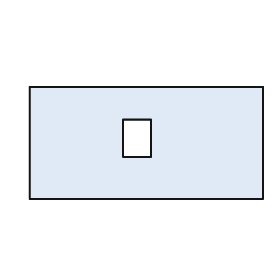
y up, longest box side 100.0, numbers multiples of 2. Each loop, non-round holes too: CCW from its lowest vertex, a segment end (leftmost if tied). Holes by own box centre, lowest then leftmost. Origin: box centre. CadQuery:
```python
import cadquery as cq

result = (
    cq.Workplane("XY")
    .moveTo(-50.0, -24.0)
    .lineTo(50.0, -24.0)
    .lineTo(50.0, 24.0)
    .lineTo(-50.0, 24.0)
    .close()
    .moveTo(-10.0, -6.0)
    .lineTo(2.0, -6.0)
    .lineTo(2.0, 10.0)
    .lineTo(-10.0, 10.0)
    .close()
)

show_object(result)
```